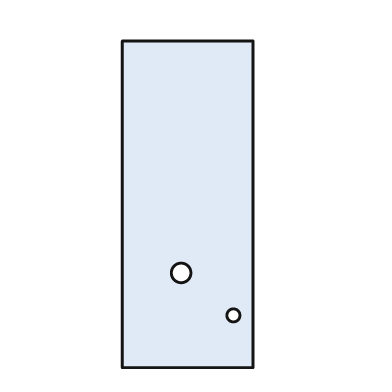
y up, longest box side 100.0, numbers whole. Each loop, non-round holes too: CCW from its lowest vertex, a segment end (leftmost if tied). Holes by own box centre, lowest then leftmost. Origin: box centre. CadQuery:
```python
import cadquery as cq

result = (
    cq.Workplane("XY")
    .moveTo(-20.0, -50.0)
    .lineTo(20.0, -50.0)
    .lineTo(20.0, 50.0)
    .lineTo(-20.0, 50.0)
    .close()
    .moveTo(14.0, -34.0)
    .circle(2.0)
    .moveTo(-2.0, -21.0)
    .circle(3.0)
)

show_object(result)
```